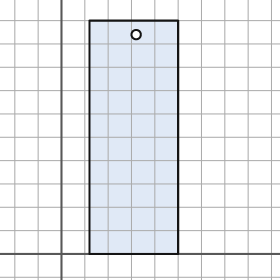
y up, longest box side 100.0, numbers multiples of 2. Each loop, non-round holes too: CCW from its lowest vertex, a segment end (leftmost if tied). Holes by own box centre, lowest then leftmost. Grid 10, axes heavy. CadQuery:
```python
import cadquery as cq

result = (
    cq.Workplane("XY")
    .moveTo(12.0, 0.0)
    .lineTo(50.0, 0.0)
    .lineTo(50.0, 100.0)
    .lineTo(12.0, 100.0)
    .close()
    .moveTo(32.0, 94.0)
    .circle(2.0)
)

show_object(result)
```